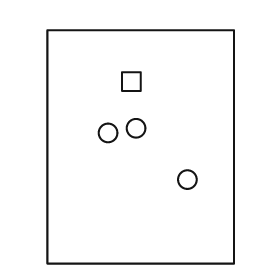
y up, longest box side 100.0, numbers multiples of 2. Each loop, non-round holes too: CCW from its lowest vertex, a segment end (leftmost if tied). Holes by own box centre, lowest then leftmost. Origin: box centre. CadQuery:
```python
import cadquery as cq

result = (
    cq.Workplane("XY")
    .moveTo(-40.0, -50.0)
    .lineTo(40.0, -50.0)
    .lineTo(40.0, 50.0)
    .lineTo(-40.0, 50.0)
    .close()
    .moveTo(20.0, -14.0)
    .circle(4.0)
    .moveTo(-14.0, 6.0)
    .circle(4.0)
    .moveTo(-2.0, 8.0)
    .circle(4.0)
    .moveTo(-8.0, 24.0)
    .lineTo(0.0, 24.0)
    .lineTo(0.0, 32.0)
    .lineTo(-8.0, 32.0)
    .close()
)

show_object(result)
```